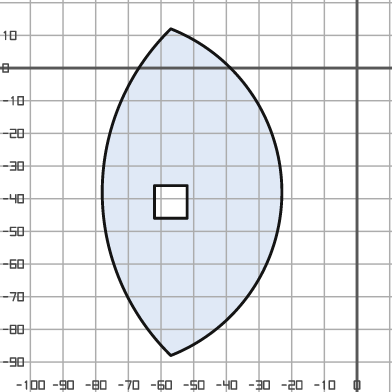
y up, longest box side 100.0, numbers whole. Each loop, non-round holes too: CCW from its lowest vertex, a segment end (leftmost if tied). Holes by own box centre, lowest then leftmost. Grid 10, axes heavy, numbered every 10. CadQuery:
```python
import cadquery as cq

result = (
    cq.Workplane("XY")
    .moveTo(-57.0, -88.0)
    .threePointArc((-23.0, -38.0), (-57.0, 12.0))
    .threePointArc((-78.0, -38.0), (-57.0, -88.0))
    .close()
    .moveTo(-62.0, -46.0)
    .lineTo(-52.0, -46.0)
    .lineTo(-52.0, -36.0)
    .lineTo(-62.0, -36.0)
    .close()
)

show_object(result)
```